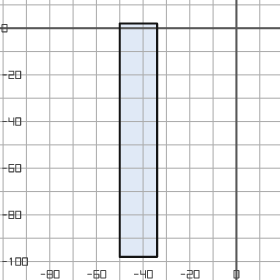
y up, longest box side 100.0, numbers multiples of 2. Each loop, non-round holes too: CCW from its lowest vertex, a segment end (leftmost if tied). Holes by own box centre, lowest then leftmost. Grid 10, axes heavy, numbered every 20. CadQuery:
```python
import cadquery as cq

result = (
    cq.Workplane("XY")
    .moveTo(-50.0, -98.0)
    .lineTo(-34.0, -98.0)
    .lineTo(-34.0, 2.0)
    .lineTo(-50.0, 2.0)
    .close()
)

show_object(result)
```